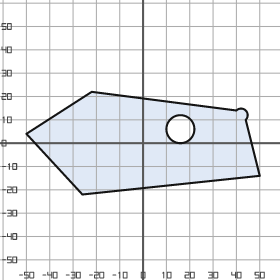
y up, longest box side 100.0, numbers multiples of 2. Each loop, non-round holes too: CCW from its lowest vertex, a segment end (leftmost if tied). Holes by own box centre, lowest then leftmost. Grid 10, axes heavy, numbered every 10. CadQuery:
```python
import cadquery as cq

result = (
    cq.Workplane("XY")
    .moveTo(-26.0, -22.0)
    .lineTo(50.0, -14.0)
    .lineTo(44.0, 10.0)
    .threePointArc((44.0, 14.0), (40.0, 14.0))
    .lineTo(-22.0, 22.0)
    .lineTo(-50.0, 4.0)
    .close()
    .moveTo(16.0, 6.0)
    .circle(6.0)
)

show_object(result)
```